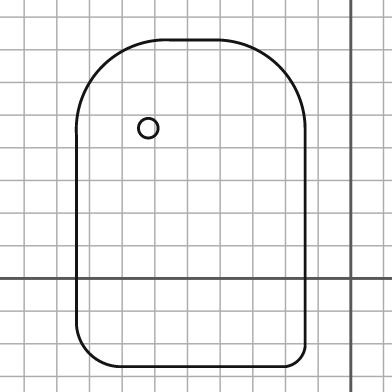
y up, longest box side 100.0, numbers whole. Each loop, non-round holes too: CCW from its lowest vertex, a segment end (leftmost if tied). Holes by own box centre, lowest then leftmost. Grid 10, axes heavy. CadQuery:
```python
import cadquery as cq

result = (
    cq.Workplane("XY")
    .moveTo(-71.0, -27.0)
    .lineTo(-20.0, -27.0)
    .threePointArc((-16.0, -25.0), (-14.0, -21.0))
    .lineTo(-14.0, 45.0)
    .threePointArc((-22.0, 65.0), (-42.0, 73.0))
    .lineTo(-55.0, 73.0)
    .threePointArc((-76.0, 65.0), (-84.0, 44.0))
    .lineTo(-84.0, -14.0)
    .threePointArc((-80.0, -23.0), (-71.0, -27.0))
    .close()
    .moveTo(-62.0, 46.0)
    .circle(3.0)
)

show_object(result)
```